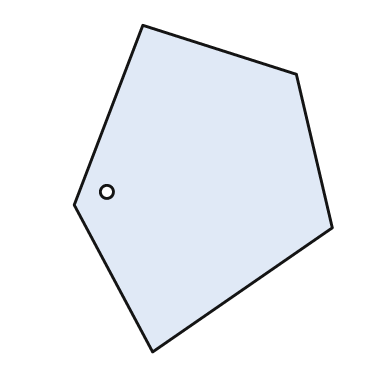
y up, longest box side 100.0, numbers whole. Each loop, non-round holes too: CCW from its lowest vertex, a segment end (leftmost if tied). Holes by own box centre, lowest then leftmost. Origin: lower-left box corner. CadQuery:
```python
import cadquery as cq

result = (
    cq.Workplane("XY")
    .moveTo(24.0, 0.0)
    .lineTo(79.0, 38.0)
    .lineTo(68.0, 85.0)
    .lineTo(21.0, 100.0)
    .lineTo(0.0, 45.0)
    .close()
    .moveTo(10.0, 49.0)
    .circle(2.0)
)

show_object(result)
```